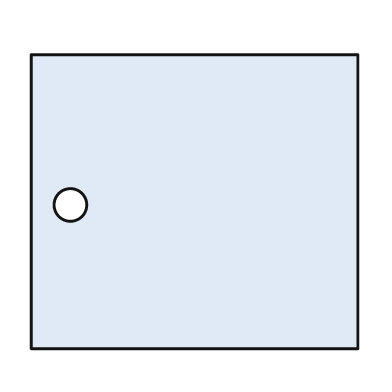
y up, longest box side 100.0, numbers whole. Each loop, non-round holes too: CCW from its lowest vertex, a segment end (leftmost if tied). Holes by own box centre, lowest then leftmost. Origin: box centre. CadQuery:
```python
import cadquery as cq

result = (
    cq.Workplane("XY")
    .moveTo(-50.0, -45.0)
    .lineTo(50.0, -45.0)
    .lineTo(50.0, 45.0)
    .lineTo(-50.0, 45.0)
    .close()
    .moveTo(-38.0, -1.0)
    .circle(5.0)
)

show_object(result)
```